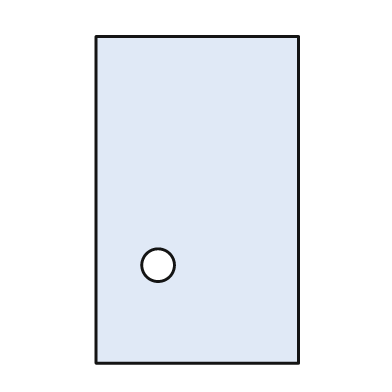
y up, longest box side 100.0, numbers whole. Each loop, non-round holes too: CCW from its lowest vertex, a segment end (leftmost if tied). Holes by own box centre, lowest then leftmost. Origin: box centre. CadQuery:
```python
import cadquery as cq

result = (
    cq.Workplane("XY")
    .moveTo(-31.0, -50.0)
    .lineTo(31.0, -50.0)
    .lineTo(31.0, 50.0)
    .lineTo(-31.0, 50.0)
    .close()
    .moveTo(-12.0, -20.0)
    .circle(5.0)
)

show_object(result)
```